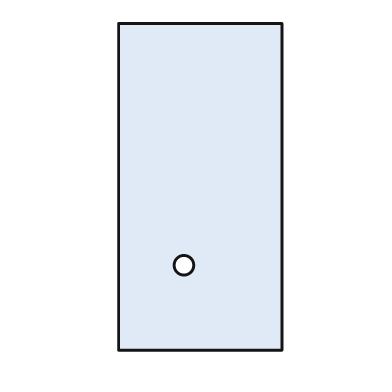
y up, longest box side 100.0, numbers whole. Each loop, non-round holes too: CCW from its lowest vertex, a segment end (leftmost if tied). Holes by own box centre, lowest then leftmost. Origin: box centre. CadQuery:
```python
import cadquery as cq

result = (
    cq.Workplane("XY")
    .moveTo(-25.0, -50.0)
    .lineTo(25.0, -50.0)
    .lineTo(25.0, 50.0)
    .lineTo(-25.0, 50.0)
    .close()
    .moveTo(-5.0, -24.0)
    .circle(3.0)
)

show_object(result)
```